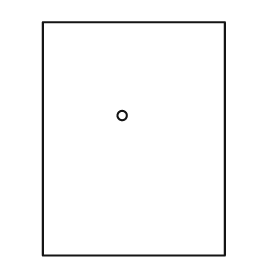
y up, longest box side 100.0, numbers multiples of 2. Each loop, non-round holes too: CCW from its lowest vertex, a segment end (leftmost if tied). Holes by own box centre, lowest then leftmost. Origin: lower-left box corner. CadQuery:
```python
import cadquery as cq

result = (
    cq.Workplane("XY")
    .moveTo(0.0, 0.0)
    .lineTo(78.0, 0.0)
    .lineTo(78.0, 100.0)
    .lineTo(0.0, 100.0)
    .close()
    .moveTo(34.0, 60.0)
    .circle(2.0)
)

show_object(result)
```